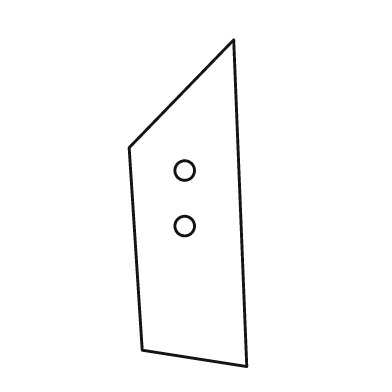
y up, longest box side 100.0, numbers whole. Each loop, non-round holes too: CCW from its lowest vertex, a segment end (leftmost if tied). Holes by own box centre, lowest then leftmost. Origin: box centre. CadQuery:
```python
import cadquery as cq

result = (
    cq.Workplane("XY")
    .moveTo(18.0, -50.0)
    .lineTo(14.0, 50.0)
    .lineTo(-18.0, 17.0)
    .lineTo(-14.0, -45.0)
    .close()
    .moveTo(-1.0, -7.0)
    .circle(3.0)
    .moveTo(-1.0, 10.0)
    .circle(3.0)
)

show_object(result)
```